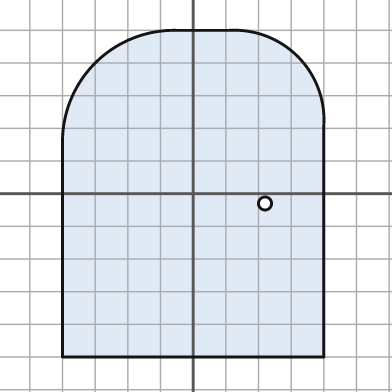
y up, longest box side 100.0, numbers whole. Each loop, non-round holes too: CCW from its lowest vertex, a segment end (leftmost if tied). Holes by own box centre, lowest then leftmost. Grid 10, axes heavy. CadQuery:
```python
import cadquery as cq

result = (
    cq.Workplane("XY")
    .moveTo(-40.0, -50.0)
    .lineTo(40.0, -50.0)
    .lineTo(40.0, 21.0)
    .threePointArc((32.0, 42.0), (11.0, 50.0))
    .lineTo(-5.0, 50.0)
    .threePointArc((-30.0, 40.0), (-40.0, 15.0))
    .close()
    .moveTo(22.0, -3.0)
    .circle(2.0)
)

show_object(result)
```